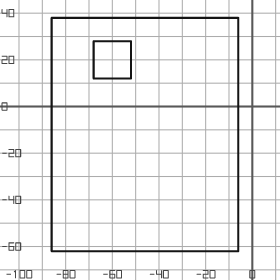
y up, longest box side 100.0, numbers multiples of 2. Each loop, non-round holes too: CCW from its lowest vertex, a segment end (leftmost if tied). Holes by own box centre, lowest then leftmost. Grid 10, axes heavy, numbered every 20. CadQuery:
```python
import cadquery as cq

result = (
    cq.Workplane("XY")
    .moveTo(-86.0, -62.0)
    .lineTo(-6.0, -62.0)
    .lineTo(-6.0, 38.0)
    .lineTo(-86.0, 38.0)
    .close()
    .moveTo(-68.0, 12.0)
    .lineTo(-52.0, 12.0)
    .lineTo(-52.0, 28.0)
    .lineTo(-68.0, 28.0)
    .close()
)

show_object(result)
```